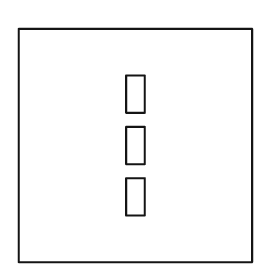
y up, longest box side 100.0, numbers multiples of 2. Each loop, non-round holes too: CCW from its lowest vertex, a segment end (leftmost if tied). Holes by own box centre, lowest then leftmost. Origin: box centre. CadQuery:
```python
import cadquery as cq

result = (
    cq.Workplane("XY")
    .moveTo(-50.0, -50.0)
    .lineTo(50.0, -50.0)
    .lineTo(50.0, 50.0)
    .lineTo(-50.0, 50.0)
    .close()
    .moveTo(-4.0, -30.0)
    .lineTo(4.0, -30.0)
    .lineTo(4.0, -14.0)
    .lineTo(-4.0, -14.0)
    .close()
    .moveTo(-4.0, -8.0)
    .lineTo(4.0, -8.0)
    .lineTo(4.0, 8.0)
    .lineTo(-4.0, 8.0)
    .close()
    .moveTo(-4.0, 14.0)
    .lineTo(4.0, 14.0)
    .lineTo(4.0, 30.0)
    .lineTo(-4.0, 30.0)
    .close()
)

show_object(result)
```